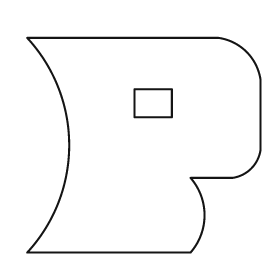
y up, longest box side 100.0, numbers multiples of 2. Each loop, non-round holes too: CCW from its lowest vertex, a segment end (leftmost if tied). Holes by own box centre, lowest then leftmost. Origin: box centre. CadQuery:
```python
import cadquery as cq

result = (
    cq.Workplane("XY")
    .moveTo(-50.0, -46.0)
    .lineTo(20.0, -46.0)
    .threePointArc((26.0, -30.0), (20.0, -14.0))
    .lineTo(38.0, -14.0)
    .threePointArc((46.0, -10.0), (50.0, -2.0))
    .lineTo(50.0, 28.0)
    .threePointArc((44.0, 40.0), (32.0, 46.0))
    .lineTo(-50.0, 46.0)
    .threePointArc((-32.0, 0.0), (-50.0, -46.0))
    .close()
    .moveTo(-4.0, 12.0)
    .lineTo(12.0, 12.0)
    .lineTo(12.0, 24.0)
    .lineTo(-4.0, 24.0)
    .close()
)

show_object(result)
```